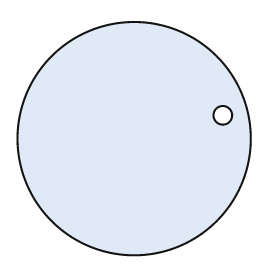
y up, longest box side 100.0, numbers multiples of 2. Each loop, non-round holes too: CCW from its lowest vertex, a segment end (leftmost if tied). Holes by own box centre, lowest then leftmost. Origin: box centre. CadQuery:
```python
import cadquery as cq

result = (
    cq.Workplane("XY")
    .moveTo(0.0, 0.0)
    .circle(50.0)
    .moveTo(38.0, 10.0)
    .circle(4.0)
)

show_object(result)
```